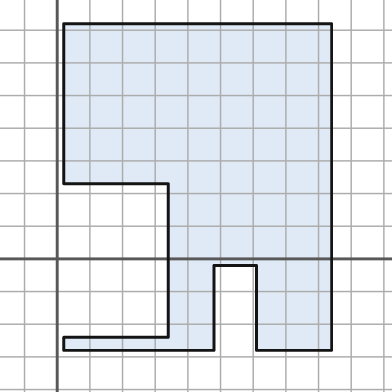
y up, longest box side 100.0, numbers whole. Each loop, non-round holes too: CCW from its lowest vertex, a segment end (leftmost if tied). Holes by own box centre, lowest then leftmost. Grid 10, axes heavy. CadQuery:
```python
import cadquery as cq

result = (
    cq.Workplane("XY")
    .moveTo(2.0, -28.0)
    .lineTo(48.0, -28.0)
    .lineTo(48.0, -2.0)
    .lineTo(61.0, -2.0)
    .lineTo(61.0, -28.0)
    .lineTo(84.0, -28.0)
    .lineTo(84.0, 72.0)
    .lineTo(2.0, 72.0)
    .lineTo(2.0, 23.0)
    .lineTo(34.0, 23.0)
    .lineTo(34.0, -24.0)
    .lineTo(2.0, -24.0)
    .close()
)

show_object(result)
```